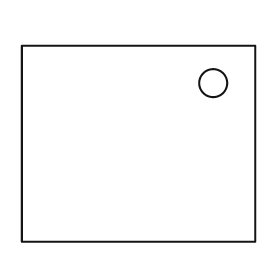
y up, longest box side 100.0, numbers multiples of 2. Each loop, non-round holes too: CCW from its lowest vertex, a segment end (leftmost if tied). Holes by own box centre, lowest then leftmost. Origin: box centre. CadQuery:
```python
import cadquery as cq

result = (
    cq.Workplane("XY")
    .moveTo(-50.0, -42.0)
    .lineTo(50.0, -42.0)
    .lineTo(50.0, 42.0)
    .lineTo(-50.0, 42.0)
    .close()
    .moveTo(32.0, 26.0)
    .circle(6.0)
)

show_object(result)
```